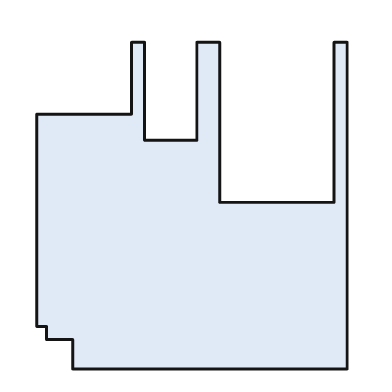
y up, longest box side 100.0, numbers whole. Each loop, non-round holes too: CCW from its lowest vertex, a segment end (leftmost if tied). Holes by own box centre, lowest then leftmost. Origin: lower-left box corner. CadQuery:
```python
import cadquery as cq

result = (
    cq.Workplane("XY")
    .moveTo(11.0, 0.0)
    .lineTo(95.0, 0.0)
    .lineTo(95.0, 100.0)
    .lineTo(91.0, 100.0)
    .lineTo(91.0, 51.0)
    .lineTo(56.0, 51.0)
    .lineTo(56.0, 100.0)
    .lineTo(49.0, 100.0)
    .lineTo(49.0, 70.0)
    .lineTo(33.0, 70.0)
    .lineTo(33.0, 100.0)
    .lineTo(29.0, 100.0)
    .lineTo(29.0, 78.0)
    .lineTo(0.0, 78.0)
    .lineTo(0.0, 13.0)
    .lineTo(3.0, 13.0)
    .lineTo(3.0, 9.0)
    .lineTo(11.0, 9.0)
    .close()
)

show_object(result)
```